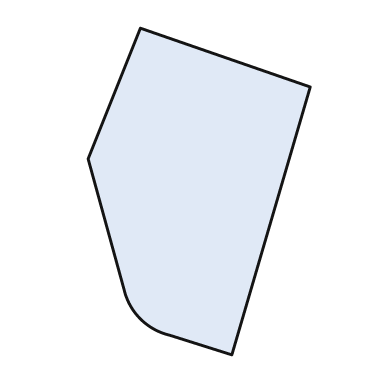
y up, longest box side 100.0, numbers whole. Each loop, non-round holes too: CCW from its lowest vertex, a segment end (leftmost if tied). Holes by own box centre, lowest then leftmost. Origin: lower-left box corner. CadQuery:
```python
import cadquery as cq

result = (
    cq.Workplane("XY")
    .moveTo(44.0, 0.0)
    .lineTo(68.0, 82.0)
    .lineTo(16.0, 100.0)
    .lineTo(0.0, 60.0)
    .lineTo(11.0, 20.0)
    .threePointArc((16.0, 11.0), (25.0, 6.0))
    .close()
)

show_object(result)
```